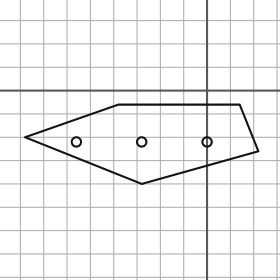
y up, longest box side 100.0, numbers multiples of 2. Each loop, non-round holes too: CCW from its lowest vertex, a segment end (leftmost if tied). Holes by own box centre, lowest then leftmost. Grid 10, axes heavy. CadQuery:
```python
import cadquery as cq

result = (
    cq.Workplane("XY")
    .moveTo(-28.0, -40.0)
    .lineTo(22.0, -26.0)
    .lineTo(14.0, -6.0)
    .lineTo(-38.0, -6.0)
    .lineTo(-78.0, -20.0)
    .close()
    .moveTo(-56.0, -22.0)
    .circle(2.0)
    .moveTo(-28.0, -22.0)
    .circle(2.0)
    .moveTo(0.0, -22.0)
    .circle(2.0)
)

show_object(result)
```